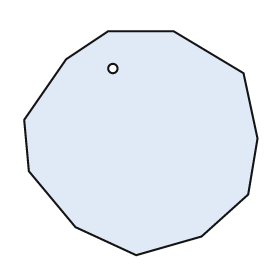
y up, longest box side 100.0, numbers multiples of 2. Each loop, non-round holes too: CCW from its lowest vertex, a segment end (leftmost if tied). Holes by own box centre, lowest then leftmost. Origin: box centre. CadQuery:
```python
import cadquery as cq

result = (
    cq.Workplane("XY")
    .moveTo(-2.0, -48.0)
    .lineTo(26.0, -40.0)
    .lineTo(46.0, -22.0)
    .lineTo(50.0, 2.0)
    .lineTo(44.0, 30.0)
    .lineTo(14.0, 48.0)
    .lineTo(-14.0, 48.0)
    .lineTo(-32.0, 36.0)
    .lineTo(-50.0, 10.0)
    .lineTo(-48.0, -12.0)
    .lineTo(-28.0, -36.0)
    .close()
    .moveTo(-12.0, 32.0)
    .circle(2.0)
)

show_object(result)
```